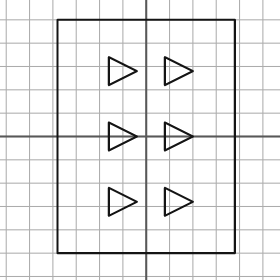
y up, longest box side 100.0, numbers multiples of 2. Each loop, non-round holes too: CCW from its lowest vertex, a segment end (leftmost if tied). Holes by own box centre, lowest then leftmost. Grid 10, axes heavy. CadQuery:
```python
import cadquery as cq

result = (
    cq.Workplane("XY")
    .moveTo(-38.0, -50.0)
    .lineTo(38.0, -50.0)
    .lineTo(38.0, 50.0)
    .lineTo(-38.0, 50.0)
    .close()
    .moveTo(-16.0, -34.0)
    .lineTo(-4.0, -28.0)
    .lineTo(-16.0, -22.0)
    .close()
    .moveTo(8.0, -34.0)
    .lineTo(20.0, -28.0)
    .lineTo(8.0, -22.0)
    .close()
    .moveTo(-16.0, -6.0)
    .lineTo(-4.0, 0.0)
    .lineTo(-16.0, 6.0)
    .close()
    .moveTo(8.0, -6.0)
    .lineTo(20.0, 0.0)
    .lineTo(8.0, 6.0)
    .close()
    .moveTo(-16.0, 22.0)
    .lineTo(-4.0, 28.0)
    .lineTo(-16.0, 34.0)
    .close()
    .moveTo(8.0, 22.0)
    .lineTo(20.0, 28.0)
    .lineTo(8.0, 34.0)
    .close()
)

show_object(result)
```